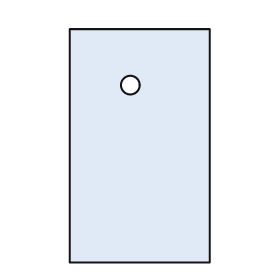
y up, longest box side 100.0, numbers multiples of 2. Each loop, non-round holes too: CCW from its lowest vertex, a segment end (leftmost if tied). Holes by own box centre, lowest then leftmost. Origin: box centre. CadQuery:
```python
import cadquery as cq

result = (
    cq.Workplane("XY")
    .moveTo(-30.0, -50.0)
    .lineTo(30.0, -50.0)
    .lineTo(30.0, 50.0)
    .lineTo(-30.0, 50.0)
    .close()
    .moveTo(-4.0, 26.0)
    .circle(4.0)
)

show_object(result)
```